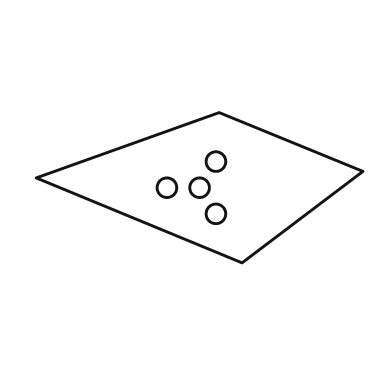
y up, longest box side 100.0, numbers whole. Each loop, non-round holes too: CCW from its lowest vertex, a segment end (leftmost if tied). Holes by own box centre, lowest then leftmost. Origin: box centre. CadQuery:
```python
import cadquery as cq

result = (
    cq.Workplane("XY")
    .moveTo(13.0, -23.0)
    .lineTo(50.0, 5.0)
    .lineTo(6.0, 23.0)
    .lineTo(-50.0, 3.0)
    .close()
    .moveTo(5.0, -8.0)
    .circle(3.0)
    .moveTo(-10.0, 0.0)
    .circle(3.0)
    .moveTo(0.0, 0.0)
    .circle(3.0)
    .moveTo(5.0, 8.0)
    .circle(3.0)
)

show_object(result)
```